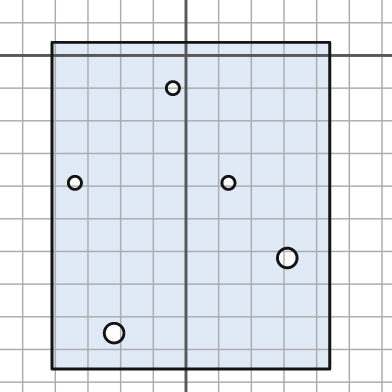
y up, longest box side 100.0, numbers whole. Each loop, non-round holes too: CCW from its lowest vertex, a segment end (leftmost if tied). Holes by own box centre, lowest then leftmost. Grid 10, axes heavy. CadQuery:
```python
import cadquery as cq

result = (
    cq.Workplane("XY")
    .moveTo(-41.0, -96.0)
    .lineTo(44.0, -96.0)
    .lineTo(44.0, 4.0)
    .lineTo(-41.0, 4.0)
    .close()
    .moveTo(-22.0, -85.0)
    .circle(3.0)
    .moveTo(31.0, -62.0)
    .circle(3.0)
    .moveTo(-34.0, -39.0)
    .circle(2.0)
    .moveTo(13.0, -39.0)
    .circle(2.0)
    .moveTo(-4.0, -10.0)
    .circle(2.0)
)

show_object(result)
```